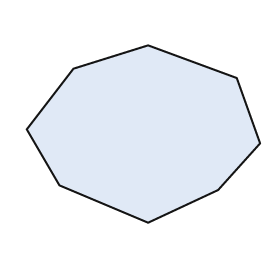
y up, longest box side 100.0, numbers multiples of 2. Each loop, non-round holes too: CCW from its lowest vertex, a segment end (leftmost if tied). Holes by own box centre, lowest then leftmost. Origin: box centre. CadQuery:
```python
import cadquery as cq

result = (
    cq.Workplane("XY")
    .moveTo(2.0, -38.0)
    .lineTo(32.0, -24.0)
    .lineTo(50.0, -4.0)
    .lineTo(40.0, 24.0)
    .lineTo(2.0, 38.0)
    .lineTo(-30.0, 28.0)
    .lineTo(-50.0, 2.0)
    .lineTo(-36.0, -22.0)
    .close()
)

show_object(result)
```